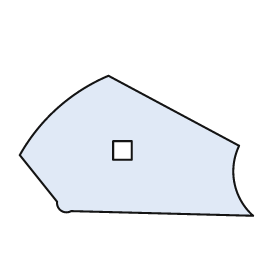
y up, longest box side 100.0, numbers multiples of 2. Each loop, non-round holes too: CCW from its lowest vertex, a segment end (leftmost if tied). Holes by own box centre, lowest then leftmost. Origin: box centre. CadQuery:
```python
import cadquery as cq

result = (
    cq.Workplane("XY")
    .moveTo(50.0, -30.0)
    .threePointArc((42.0, -16.0), (44.0, 0.0))
    .lineTo(-12.0, 30.0)
    .threePointArc((-34.0, 16.0), (-50.0, -4.0))
    .lineTo(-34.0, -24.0)
    .threePointArc((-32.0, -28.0), (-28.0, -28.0))
    .close()
    .moveTo(-10.0, -6.0)
    .lineTo(-2.0, -6.0)
    .lineTo(-2.0, 2.0)
    .lineTo(-10.0, 2.0)
    .close()
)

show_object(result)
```